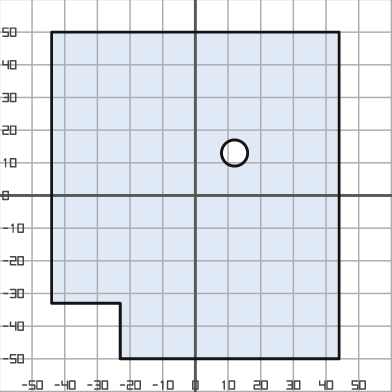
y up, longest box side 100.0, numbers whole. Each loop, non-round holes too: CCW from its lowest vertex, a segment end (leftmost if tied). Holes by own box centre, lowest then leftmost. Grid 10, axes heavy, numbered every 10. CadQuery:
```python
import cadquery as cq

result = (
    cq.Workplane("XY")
    .moveTo(-23.0, -50.0)
    .lineTo(44.0, -50.0)
    .lineTo(44.0, 50.0)
    .lineTo(-44.0, 50.0)
    .lineTo(-44.0, -33.0)
    .lineTo(-23.0, -33.0)
    .close()
    .moveTo(12.0, 13.0)
    .circle(4.0)
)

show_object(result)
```